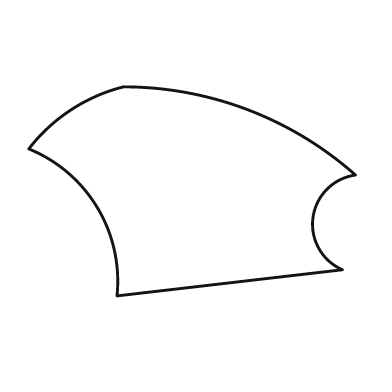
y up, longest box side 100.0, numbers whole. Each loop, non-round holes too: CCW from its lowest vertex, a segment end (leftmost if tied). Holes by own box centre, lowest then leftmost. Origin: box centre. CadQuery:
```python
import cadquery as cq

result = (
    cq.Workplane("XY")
    .moveTo(-23.0, -32.0)
    .lineTo(46.0, -24.0)
    .threePointArc((37.0, -8.0), (50.0, 5.0))
    .threePointArc((17.0, 25.0), (-21.0, 32.0))
    .threePointArc((-37.0, 25.0), (-50.0, 13.0))
    .threePointArc((-29.0, -5.0), (-23.0, -32.0))
    .close()
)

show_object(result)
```